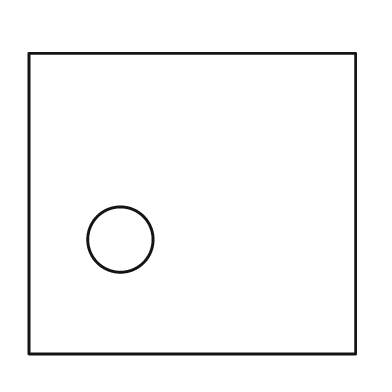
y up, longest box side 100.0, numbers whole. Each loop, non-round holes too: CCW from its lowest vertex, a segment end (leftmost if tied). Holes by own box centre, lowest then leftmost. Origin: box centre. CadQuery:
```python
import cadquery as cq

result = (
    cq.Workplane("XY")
    .moveTo(-50.0, -46.0)
    .lineTo(50.0, -46.0)
    .lineTo(50.0, 46.0)
    .lineTo(-50.0, 46.0)
    .close()
    .moveTo(-22.0, -11.0)
    .circle(10.0)
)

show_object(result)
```